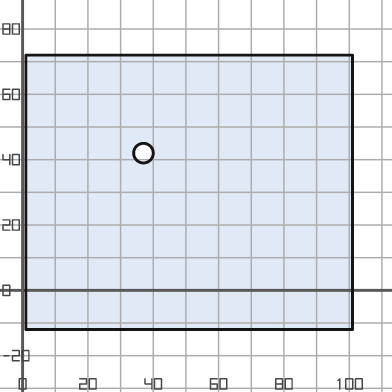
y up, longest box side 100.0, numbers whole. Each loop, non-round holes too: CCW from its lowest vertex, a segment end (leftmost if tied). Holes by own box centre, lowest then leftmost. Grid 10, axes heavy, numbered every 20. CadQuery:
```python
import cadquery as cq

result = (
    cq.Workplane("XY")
    .moveTo(1.0, -12.0)
    .lineTo(101.0, -12.0)
    .lineTo(101.0, 72.0)
    .lineTo(1.0, 72.0)
    .close()
    .moveTo(37.0, 42.0)
    .circle(3.0)
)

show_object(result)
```